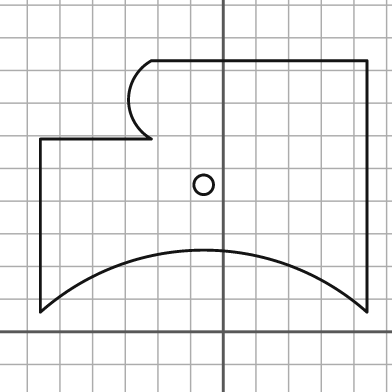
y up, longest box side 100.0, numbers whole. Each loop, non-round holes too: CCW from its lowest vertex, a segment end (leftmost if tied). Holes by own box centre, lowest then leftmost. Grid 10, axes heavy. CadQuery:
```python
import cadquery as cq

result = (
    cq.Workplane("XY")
    .moveTo(-56.0, 6.0)
    .threePointArc((-6.0, 25.0), (44.0, 6.0))
    .lineTo(44.0, 83.0)
    .lineTo(-22.0, 83.0)
    .threePointArc((-29.0, 71.0), (-22.0, 59.0))
    .lineTo(-56.0, 59.0)
    .close()
    .moveTo(-6.0, 45.0)
    .circle(3.0)
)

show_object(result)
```